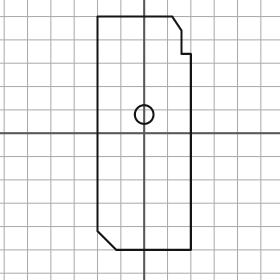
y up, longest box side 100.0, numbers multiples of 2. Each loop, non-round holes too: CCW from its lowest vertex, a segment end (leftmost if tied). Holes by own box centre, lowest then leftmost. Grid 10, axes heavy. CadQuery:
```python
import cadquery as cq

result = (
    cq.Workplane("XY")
    .moveTo(-12.0, -50.0)
    .lineTo(20.0, -50.0)
    .lineTo(20.0, 34.0)
    .lineTo(16.0, 34.0)
    .lineTo(16.0, 44.0)
    .lineTo(12.0, 50.0)
    .lineTo(-20.0, 50.0)
    .lineTo(-20.0, -42.0)
    .close()
    .moveTo(0.0, 8.0)
    .circle(4.0)
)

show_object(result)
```